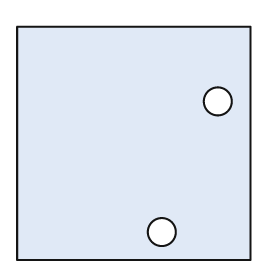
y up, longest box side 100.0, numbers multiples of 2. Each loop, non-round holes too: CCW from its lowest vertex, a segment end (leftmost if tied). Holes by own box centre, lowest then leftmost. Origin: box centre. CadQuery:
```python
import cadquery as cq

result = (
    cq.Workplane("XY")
    .moveTo(-50.0, -50.0)
    .lineTo(50.0, -50.0)
    .lineTo(50.0, 50.0)
    .lineTo(-50.0, 50.0)
    .close()
    .moveTo(12.0, -38.0)
    .circle(6.0)
    .moveTo(36.0, 18.0)
    .circle(6.0)
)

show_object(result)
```